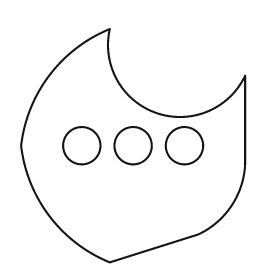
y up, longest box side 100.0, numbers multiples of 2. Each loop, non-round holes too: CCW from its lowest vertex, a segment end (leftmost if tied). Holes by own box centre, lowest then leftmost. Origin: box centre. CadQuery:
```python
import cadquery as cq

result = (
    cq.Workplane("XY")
    .moveTo(-10.0, -50.0)
    .lineTo(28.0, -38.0)
    .threePointArc((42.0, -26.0), (48.0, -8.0))
    .lineTo(48.0, 30.0)
    .threePointArc((10.0, 14.0), (-10.0, 50.0))
    .threePointArc((-36.0, 30.0), (-48.0, 0.0))
    .threePointArc((-36.0, -30.0), (-10.0, -50.0))
    .close()
    .moveTo(-22.0, 0.0)
    .circle(8.0)
    .moveTo(0.0, 0.0)
    .circle(8.0)
    .moveTo(22.0, 0.0)
    .circle(8.0)
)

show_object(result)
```